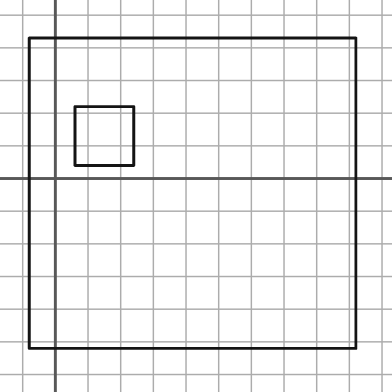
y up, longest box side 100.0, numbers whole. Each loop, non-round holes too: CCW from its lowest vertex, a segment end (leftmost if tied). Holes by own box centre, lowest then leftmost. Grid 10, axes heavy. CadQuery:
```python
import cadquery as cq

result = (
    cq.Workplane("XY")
    .moveTo(-8.0, -52.0)
    .lineTo(92.0, -52.0)
    .lineTo(92.0, 43.0)
    .lineTo(-8.0, 43.0)
    .close()
    .moveTo(6.0, 4.0)
    .lineTo(24.0, 4.0)
    .lineTo(24.0, 22.0)
    .lineTo(6.0, 22.0)
    .close()
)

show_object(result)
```